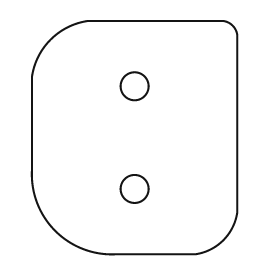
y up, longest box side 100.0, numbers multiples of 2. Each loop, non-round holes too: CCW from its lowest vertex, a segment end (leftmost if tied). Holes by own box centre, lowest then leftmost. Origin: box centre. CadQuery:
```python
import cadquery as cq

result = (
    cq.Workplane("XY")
    .moveTo(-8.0, -50.0)
    .lineTo(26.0, -50.0)
    .threePointArc((38.0, -44.0), (44.0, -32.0))
    .lineTo(44.0, 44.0)
    .threePointArc((42.0, 48.0), (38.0, 50.0))
    .lineTo(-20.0, 50.0)
    .threePointArc((-36.0, 42.0), (-44.0, 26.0))
    .lineTo(-44.0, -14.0)
    .threePointArc((-34.0, -40.0), (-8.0, -50.0))
    .close()
    .moveTo(0.0, -22.0)
    .circle(6.0)
    .moveTo(0.0, 22.0)
    .circle(6.0)
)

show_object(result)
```